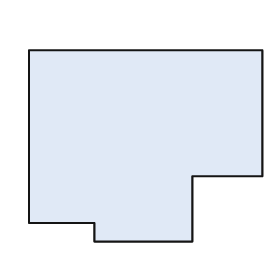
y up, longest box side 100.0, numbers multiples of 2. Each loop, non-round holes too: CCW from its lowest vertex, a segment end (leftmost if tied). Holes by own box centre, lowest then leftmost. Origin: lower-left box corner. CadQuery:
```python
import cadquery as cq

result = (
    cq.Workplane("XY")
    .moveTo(28.0, 0.0)
    .lineTo(70.0, 0.0)
    .lineTo(70.0, 28.0)
    .lineTo(100.0, 28.0)
    .lineTo(100.0, 82.0)
    .lineTo(0.0, 82.0)
    .lineTo(0.0, 8.0)
    .lineTo(28.0, 8.0)
    .close()
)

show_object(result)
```